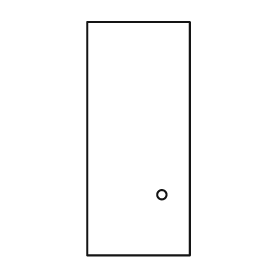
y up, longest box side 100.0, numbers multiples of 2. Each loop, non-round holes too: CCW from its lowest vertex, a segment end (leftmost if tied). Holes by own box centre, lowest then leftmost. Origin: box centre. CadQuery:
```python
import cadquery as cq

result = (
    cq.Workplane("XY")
    .moveTo(-22.0, -50.0)
    .lineTo(22.0, -50.0)
    .lineTo(22.0, 50.0)
    .lineTo(-22.0, 50.0)
    .close()
    .moveTo(10.0, -24.0)
    .circle(2.0)
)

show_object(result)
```